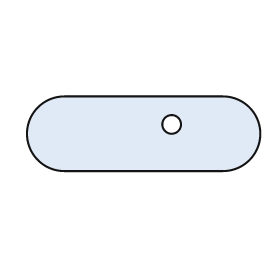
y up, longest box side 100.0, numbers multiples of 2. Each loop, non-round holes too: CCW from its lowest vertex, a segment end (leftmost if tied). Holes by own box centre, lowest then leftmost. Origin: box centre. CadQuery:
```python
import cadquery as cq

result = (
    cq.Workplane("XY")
    .moveTo(-34.0, -16.0)
    .lineTo(34.0, -16.0)
    .threePointArc((50.0, 0.0), (34.0, 16.0))
    .lineTo(-34.0, 16.0)
    .threePointArc((-50.0, 0.0), (-34.0, -16.0))
    .close()
    .moveTo(12.0, 4.0)
    .circle(4.0)
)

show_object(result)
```